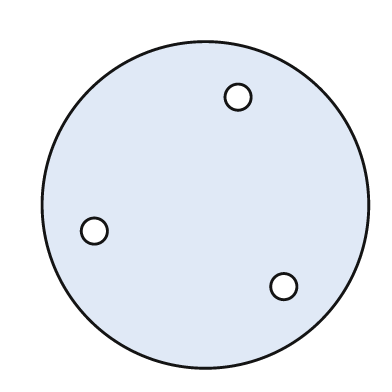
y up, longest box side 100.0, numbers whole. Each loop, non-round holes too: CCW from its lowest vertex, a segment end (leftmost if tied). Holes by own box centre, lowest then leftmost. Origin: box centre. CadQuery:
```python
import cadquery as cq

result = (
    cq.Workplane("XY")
    .moveTo(0.0, 0.0)
    .circle(50.0)
    .moveTo(24.0, -25.0)
    .circle(4.0)
    .moveTo(-34.0, -8.0)
    .circle(4.0)
    .moveTo(10.0, 33.0)
    .circle(4.0)
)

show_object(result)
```